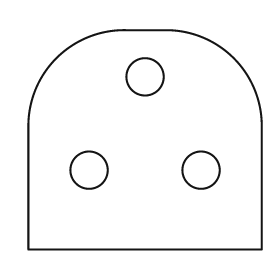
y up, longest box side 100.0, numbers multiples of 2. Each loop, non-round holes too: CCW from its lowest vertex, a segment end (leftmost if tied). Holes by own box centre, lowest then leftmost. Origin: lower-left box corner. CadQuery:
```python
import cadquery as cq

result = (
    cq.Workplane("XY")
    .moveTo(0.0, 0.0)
    .lineTo(100.0, 0.0)
    .lineTo(100.0, 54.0)
    .threePointArc((88.0, 82.0), (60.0, 94.0))
    .lineTo(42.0, 94.0)
    .threePointArc((12.0, 82.0), (0.0, 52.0))
    .close()
    .moveTo(26.0, 34.0)
    .circle(8.0)
    .moveTo(74.0, 34.0)
    .circle(8.0)
    .moveTo(50.0, 74.0)
    .circle(8.0)
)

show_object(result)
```